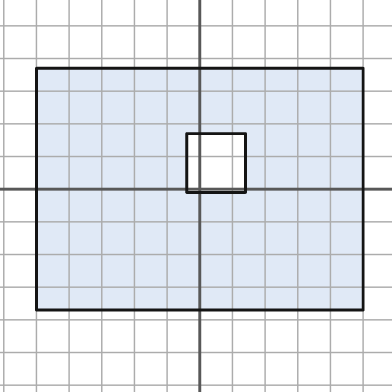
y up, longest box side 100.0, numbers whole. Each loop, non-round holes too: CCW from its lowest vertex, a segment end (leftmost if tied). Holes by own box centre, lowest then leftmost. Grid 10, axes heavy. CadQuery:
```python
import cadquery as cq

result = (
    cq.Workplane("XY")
    .moveTo(-50.0, -37.0)
    .lineTo(50.0, -37.0)
    .lineTo(50.0, 37.0)
    .lineTo(-50.0, 37.0)
    .close()
    .moveTo(-4.0, -1.0)
    .lineTo(14.0, -1.0)
    .lineTo(14.0, 17.0)
    .lineTo(-4.0, 17.0)
    .close()
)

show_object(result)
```